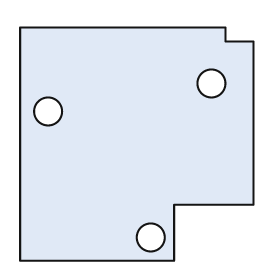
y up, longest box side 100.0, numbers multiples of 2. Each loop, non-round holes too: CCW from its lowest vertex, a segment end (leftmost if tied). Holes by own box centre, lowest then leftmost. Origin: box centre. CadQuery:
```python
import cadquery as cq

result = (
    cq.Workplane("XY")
    .moveTo(-50.0, -50.0)
    .lineTo(16.0, -50.0)
    .lineTo(16.0, -26.0)
    .lineTo(50.0, -26.0)
    .lineTo(50.0, 44.0)
    .lineTo(38.0, 44.0)
    .lineTo(38.0, 50.0)
    .lineTo(-50.0, 50.0)
    .close()
    .moveTo(6.0, -40.0)
    .circle(6.0)
    .moveTo(-38.0, 14.0)
    .circle(6.0)
    .moveTo(32.0, 26.0)
    .circle(6.0)
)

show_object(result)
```